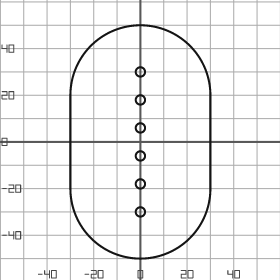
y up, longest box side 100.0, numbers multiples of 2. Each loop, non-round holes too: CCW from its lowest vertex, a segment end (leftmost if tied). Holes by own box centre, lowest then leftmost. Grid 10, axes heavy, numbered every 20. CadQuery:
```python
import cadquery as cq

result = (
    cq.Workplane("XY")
    .moveTo(-30.0, -20.0)
    .threePointArc((0.0, -50.0), (30.0, -20.0))
    .lineTo(30.0, 20.0)
    .threePointArc((0.0, 50.0), (-30.0, 20.0))
    .close()
    .moveTo(0.0, -30.0)
    .circle(2.0)
    .moveTo(0.0, -18.0)
    .circle(2.0)
    .moveTo(0.0, -6.0)
    .circle(2.0)
    .moveTo(0.0, 6.0)
    .circle(2.0)
    .moveTo(0.0, 18.0)
    .circle(2.0)
    .moveTo(0.0, 30.0)
    .circle(2.0)
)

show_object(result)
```